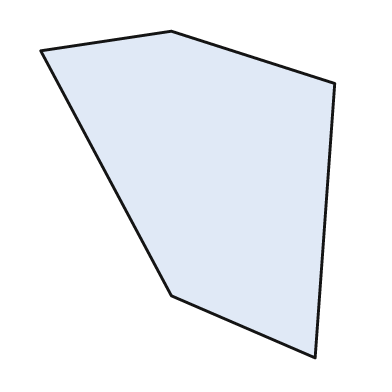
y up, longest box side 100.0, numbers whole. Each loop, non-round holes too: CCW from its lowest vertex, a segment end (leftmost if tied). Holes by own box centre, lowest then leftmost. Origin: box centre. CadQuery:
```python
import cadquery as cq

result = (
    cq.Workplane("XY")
    .moveTo(39.0, -50.0)
    .lineTo(45.0, 34.0)
    .lineTo(-5.0, 50.0)
    .lineTo(-45.0, 44.0)
    .lineTo(-5.0, -31.0)
    .close()
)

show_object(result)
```